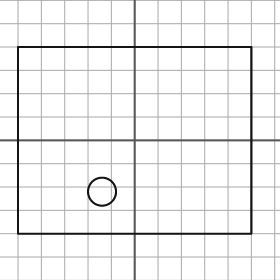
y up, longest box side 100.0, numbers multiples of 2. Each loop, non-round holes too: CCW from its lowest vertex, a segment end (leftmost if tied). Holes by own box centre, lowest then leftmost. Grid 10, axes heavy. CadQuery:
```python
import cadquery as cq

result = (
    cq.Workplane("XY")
    .moveTo(-50.0, -40.0)
    .lineTo(50.0, -40.0)
    .lineTo(50.0, 40.0)
    .lineTo(-50.0, 40.0)
    .close()
    .moveTo(-14.0, -22.0)
    .circle(6.0)
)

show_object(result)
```